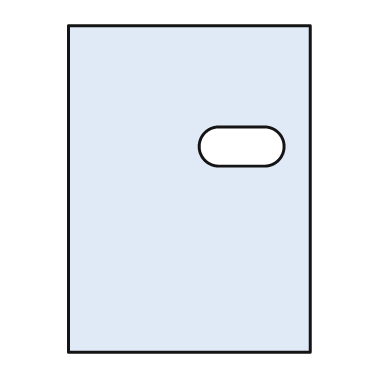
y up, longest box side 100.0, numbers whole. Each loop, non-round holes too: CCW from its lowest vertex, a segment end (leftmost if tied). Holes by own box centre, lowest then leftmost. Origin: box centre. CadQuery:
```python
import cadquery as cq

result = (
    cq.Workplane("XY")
    .moveTo(-37.0, -50.0)
    .lineTo(37.0, -50.0)
    .lineTo(37.0, 50.0)
    .lineTo(-37.0, 50.0)
    .close()
    .moveTo(9.0, 7.0)
    .lineTo(23.0, 7.0)
    .threePointArc((29.0, 13.0), (23.0, 19.0))
    .lineTo(9.0, 19.0)
    .threePointArc((3.0, 13.0), (9.0, 7.0))
    .close()
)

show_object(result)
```